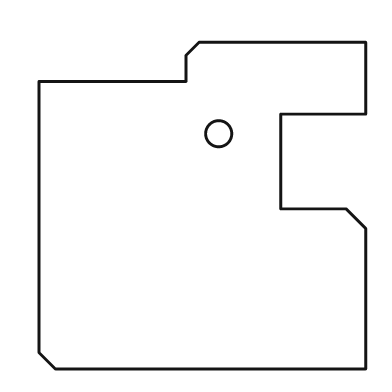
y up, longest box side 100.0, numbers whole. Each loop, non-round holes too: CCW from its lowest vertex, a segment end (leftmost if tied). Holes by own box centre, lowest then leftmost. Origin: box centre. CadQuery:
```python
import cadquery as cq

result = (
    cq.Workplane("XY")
    .moveTo(-45.0, -50.0)
    .lineTo(50.0, -50.0)
    .lineTo(50.0, -7.0)
    .lineTo(44.0, -1.0)
    .lineTo(24.0, -1.0)
    .lineTo(24.0, 28.0)
    .lineTo(50.0, 28.0)
    .lineTo(50.0, 50.0)
    .lineTo(-1.0, 50.0)
    .lineTo(-5.0, 46.0)
    .lineTo(-5.0, 38.0)
    .lineTo(-50.0, 38.0)
    .lineTo(-50.0, -45.0)
    .close()
    .moveTo(5.0, 22.0)
    .circle(4.0)
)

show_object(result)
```